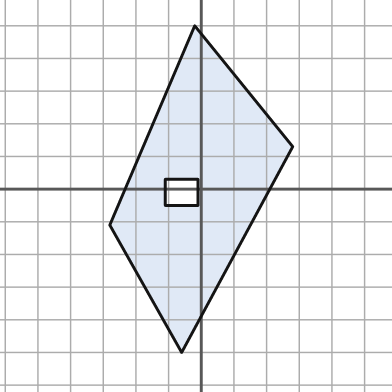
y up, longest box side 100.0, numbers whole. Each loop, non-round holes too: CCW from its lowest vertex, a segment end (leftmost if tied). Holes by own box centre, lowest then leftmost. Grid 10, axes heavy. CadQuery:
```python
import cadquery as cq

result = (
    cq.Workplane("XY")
    .moveTo(-6.0, -50.0)
    .lineTo(28.0, 13.0)
    .lineTo(-2.0, 50.0)
    .lineTo(-28.0, -11.0)
    .close()
    .moveTo(-11.0, -5.0)
    .lineTo(-1.0, -5.0)
    .lineTo(-1.0, 3.0)
    .lineTo(-11.0, 3.0)
    .close()
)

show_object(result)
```